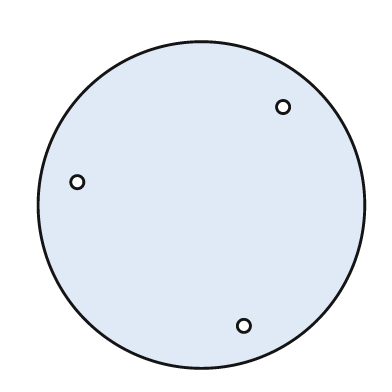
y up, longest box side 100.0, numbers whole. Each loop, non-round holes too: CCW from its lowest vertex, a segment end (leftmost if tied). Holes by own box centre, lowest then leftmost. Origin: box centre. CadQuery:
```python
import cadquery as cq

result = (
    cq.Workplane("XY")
    .moveTo(0.0, 0.0)
    .circle(50.0)
    .moveTo(13.0, -37.0)
    .circle(2.0)
    .moveTo(-38.0, 7.0)
    .circle(2.0)
    .moveTo(25.0, 30.0)
    .circle(2.0)
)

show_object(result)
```